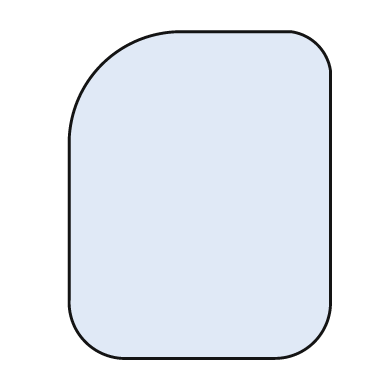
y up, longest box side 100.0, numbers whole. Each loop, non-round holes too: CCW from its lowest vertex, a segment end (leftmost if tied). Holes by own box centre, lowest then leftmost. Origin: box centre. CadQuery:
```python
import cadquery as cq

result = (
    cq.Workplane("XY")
    .moveTo(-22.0, -50.0)
    .lineTo(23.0, -50.0)
    .threePointArc((35.0, -45.0), (40.0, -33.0))
    .lineTo(40.0, 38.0)
    .threePointArc((36.0, 46.0), (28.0, 50.0))
    .lineTo(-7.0, 50.0)
    .threePointArc((-30.0, 40.0), (-40.0, 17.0))
    .lineTo(-40.0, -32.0)
    .threePointArc((-35.0, -45.0), (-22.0, -50.0))
    .close()
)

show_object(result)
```